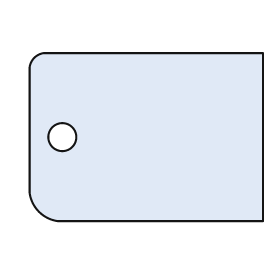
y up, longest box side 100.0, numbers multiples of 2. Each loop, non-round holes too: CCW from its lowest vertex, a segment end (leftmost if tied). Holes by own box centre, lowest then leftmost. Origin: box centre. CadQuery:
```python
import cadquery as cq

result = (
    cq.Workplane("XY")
    .moveTo(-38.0, -36.0)
    .lineTo(50.0, -36.0)
    .lineTo(50.0, 36.0)
    .lineTo(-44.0, 36.0)
    .threePointArc((-48.0, 34.0), (-50.0, 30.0))
    .lineTo(-50.0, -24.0)
    .threePointArc((-46.0, -32.0), (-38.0, -36.0))
    .close()
    .moveTo(-36.0, 0.0)
    .circle(6.0)
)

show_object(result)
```